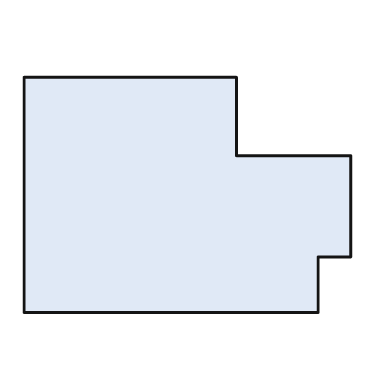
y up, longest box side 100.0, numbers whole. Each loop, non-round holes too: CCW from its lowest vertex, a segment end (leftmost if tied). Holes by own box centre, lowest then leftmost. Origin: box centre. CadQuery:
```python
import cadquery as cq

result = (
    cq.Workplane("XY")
    .moveTo(-50.0, -36.0)
    .lineTo(40.0, -36.0)
    .lineTo(40.0, -19.0)
    .lineTo(50.0, -19.0)
    .lineTo(50.0, 12.0)
    .lineTo(15.0, 12.0)
    .lineTo(15.0, 36.0)
    .lineTo(-50.0, 36.0)
    .close()
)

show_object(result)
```